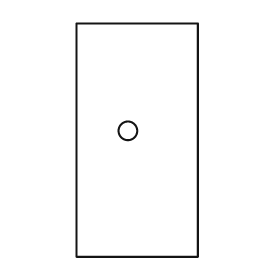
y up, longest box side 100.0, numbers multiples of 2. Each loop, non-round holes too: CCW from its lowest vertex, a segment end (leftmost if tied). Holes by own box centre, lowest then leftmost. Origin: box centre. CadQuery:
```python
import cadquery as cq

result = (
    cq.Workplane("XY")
    .moveTo(-26.0, -50.0)
    .lineTo(26.0, -50.0)
    .lineTo(26.0, 50.0)
    .lineTo(-26.0, 50.0)
    .close()
    .moveTo(-4.0, 4.0)
    .circle(4.0)
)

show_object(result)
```